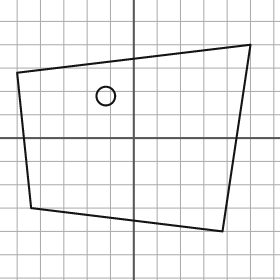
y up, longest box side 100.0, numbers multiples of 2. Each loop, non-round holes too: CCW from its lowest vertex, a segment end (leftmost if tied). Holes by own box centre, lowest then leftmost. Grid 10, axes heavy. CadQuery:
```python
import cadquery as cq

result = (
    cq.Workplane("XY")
    .moveTo(38.0, -40.0)
    .lineTo(50.0, 40.0)
    .lineTo(-50.0, 28.0)
    .lineTo(-44.0, -30.0)
    .close()
    .moveTo(-12.0, 18.0)
    .circle(4.0)
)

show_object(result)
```